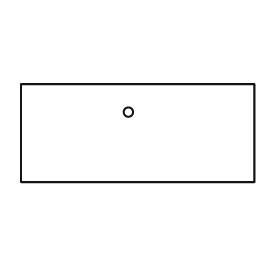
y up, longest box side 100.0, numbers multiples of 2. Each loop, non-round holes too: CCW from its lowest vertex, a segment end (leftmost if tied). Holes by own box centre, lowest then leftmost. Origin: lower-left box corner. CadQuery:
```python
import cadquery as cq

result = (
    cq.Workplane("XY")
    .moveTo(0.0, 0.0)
    .lineTo(100.0, 0.0)
    .lineTo(100.0, 42.0)
    .lineTo(0.0, 42.0)
    .close()
    .moveTo(46.0, 30.0)
    .circle(2.0)
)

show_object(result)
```